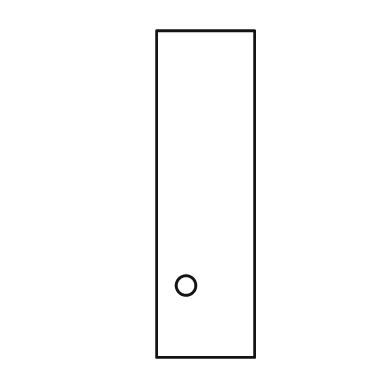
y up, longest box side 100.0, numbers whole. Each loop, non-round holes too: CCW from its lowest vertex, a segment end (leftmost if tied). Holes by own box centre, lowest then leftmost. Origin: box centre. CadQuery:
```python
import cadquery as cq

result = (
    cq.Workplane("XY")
    .moveTo(-15.0, -50.0)
    .lineTo(15.0, -50.0)
    .lineTo(15.0, 50.0)
    .lineTo(-15.0, 50.0)
    .close()
    .moveTo(-6.0, -28.0)
    .circle(3.0)
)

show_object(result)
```